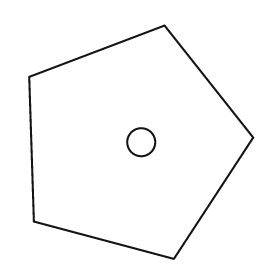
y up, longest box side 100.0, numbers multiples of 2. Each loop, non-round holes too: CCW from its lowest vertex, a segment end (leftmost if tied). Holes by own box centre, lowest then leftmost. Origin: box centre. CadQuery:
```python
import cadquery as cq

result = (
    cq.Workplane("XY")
    .moveTo(14.0, -50.0)
    .lineTo(48.0, 2.0)
    .lineTo(10.0, 50.0)
    .lineTo(-48.0, 28.0)
    .lineTo(-46.0, -34.0)
    .close()
    .moveTo(0.0, 0.0)
    .circle(6.0)
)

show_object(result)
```